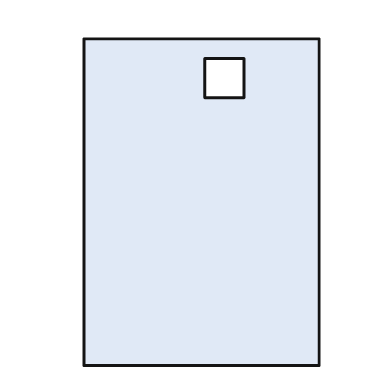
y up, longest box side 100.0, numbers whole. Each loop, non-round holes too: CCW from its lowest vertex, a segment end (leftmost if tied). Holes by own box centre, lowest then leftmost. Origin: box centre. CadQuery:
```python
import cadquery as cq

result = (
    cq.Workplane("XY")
    .moveTo(-36.0, -50.0)
    .lineTo(36.0, -50.0)
    .lineTo(36.0, 50.0)
    .lineTo(-36.0, 50.0)
    .close()
    .moveTo(1.0, 32.0)
    .lineTo(13.0, 32.0)
    .lineTo(13.0, 44.0)
    .lineTo(1.0, 44.0)
    .close()
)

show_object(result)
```